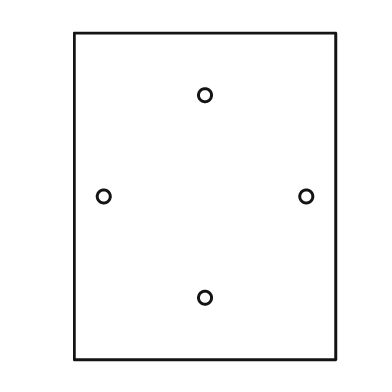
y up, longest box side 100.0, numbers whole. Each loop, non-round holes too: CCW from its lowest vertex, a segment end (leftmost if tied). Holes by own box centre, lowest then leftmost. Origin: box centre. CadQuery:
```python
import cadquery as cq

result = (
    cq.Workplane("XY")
    .moveTo(-40.0, -50.0)
    .lineTo(40.0, -50.0)
    .lineTo(40.0, 50.0)
    .lineTo(-40.0, 50.0)
    .close()
    .moveTo(0.0, -31.0)
    .circle(2.0)
    .moveTo(-31.0, 0.0)
    .circle(2.0)
    .moveTo(31.0, 0.0)
    .circle(2.0)
    .moveTo(0.0, 31.0)
    .circle(2.0)
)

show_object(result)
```